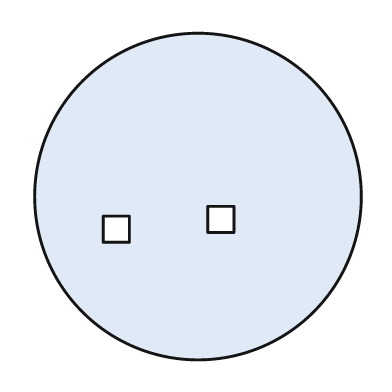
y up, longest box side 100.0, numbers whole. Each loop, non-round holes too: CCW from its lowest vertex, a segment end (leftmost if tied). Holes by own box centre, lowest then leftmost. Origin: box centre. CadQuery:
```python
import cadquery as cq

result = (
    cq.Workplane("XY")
    .moveTo(0.0, 0.0)
    .circle(50.0)
    .moveTo(-29.0, -14.0)
    .lineTo(-21.0, -14.0)
    .lineTo(-21.0, -6.0)
    .lineTo(-29.0, -6.0)
    .close()
    .moveTo(3.0, -11.0)
    .lineTo(11.0, -11.0)
    .lineTo(11.0, -3.0)
    .lineTo(3.0, -3.0)
    .close()
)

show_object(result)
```